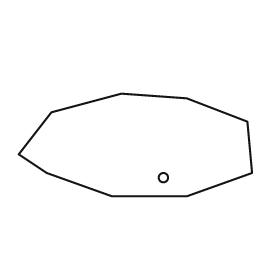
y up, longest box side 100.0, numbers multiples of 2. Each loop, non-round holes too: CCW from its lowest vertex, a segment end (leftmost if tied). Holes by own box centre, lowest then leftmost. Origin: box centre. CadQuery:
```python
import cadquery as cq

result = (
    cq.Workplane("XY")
    .moveTo(-10.0, -22.0)
    .lineTo(22.0, -22.0)
    .lineTo(50.0, -12.0)
    .lineTo(48.0, 10.0)
    .lineTo(22.0, 20.0)
    .lineTo(-6.0, 22.0)
    .lineTo(-36.0, 14.0)
    .lineTo(-50.0, -4.0)
    .lineTo(-38.0, -12.0)
    .close()
    .moveTo(12.0, -14.0)
    .circle(2.0)
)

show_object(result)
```